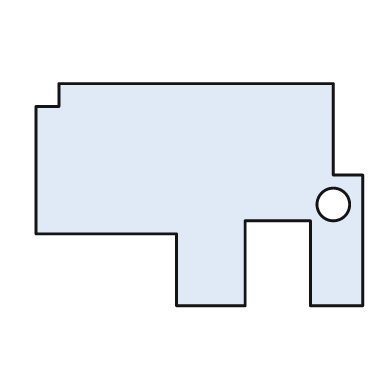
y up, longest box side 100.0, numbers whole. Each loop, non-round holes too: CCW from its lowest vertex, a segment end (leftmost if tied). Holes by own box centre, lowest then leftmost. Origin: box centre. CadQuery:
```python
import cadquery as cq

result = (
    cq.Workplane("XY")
    .moveTo(-7.0, -34.0)
    .lineTo(14.0, -34.0)
    .lineTo(14.0, -8.0)
    .lineTo(34.0, -8.0)
    .lineTo(34.0, -34.0)
    .lineTo(50.0, -34.0)
    .lineTo(50.0, 6.0)
    .lineTo(41.0, 6.0)
    .lineTo(41.0, 34.0)
    .lineTo(-43.0, 34.0)
    .lineTo(-43.0, 27.0)
    .lineTo(-50.0, 27.0)
    .lineTo(-50.0, -12.0)
    .lineTo(-7.0, -12.0)
    .close()
    .moveTo(41.0, -3.0)
    .circle(5.0)
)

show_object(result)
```